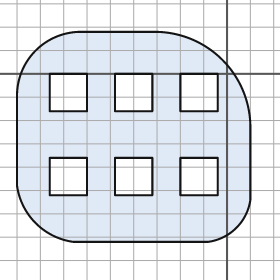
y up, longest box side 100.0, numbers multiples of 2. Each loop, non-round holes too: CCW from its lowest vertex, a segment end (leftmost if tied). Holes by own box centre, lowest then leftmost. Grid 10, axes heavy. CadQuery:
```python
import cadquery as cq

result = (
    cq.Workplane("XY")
    .moveTo(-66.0, -72.0)
    .lineTo(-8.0, -72.0)
    .threePointArc((4.0, -66.0), (10.0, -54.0))
    .lineTo(10.0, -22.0)
    .threePointArc((-2.0, 6.0), (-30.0, 18.0))
    .lineTo(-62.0, 18.0)
    .threePointArc((-82.0, 10.0), (-90.0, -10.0))
    .lineTo(-90.0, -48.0)
    .threePointArc((-82.0, -64.0), (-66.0, -72.0))
    .close()
    .moveTo(-76.0, -52.0)
    .lineTo(-60.0, -52.0)
    .lineTo(-60.0, -36.0)
    .lineTo(-76.0, -36.0)
    .close()
    .moveTo(-48.0, -52.0)
    .lineTo(-32.0, -52.0)
    .lineTo(-32.0, -36.0)
    .lineTo(-48.0, -36.0)
    .close()
    .moveTo(-20.0, -52.0)
    .lineTo(-4.0, -52.0)
    .lineTo(-4.0, -36.0)
    .lineTo(-20.0, -36.0)
    .close()
    .moveTo(-76.0, -16.0)
    .lineTo(-60.0, -16.0)
    .lineTo(-60.0, 0.0)
    .lineTo(-76.0, 0.0)
    .close()
    .moveTo(-48.0, -16.0)
    .lineTo(-32.0, -16.0)
    .lineTo(-32.0, 0.0)
    .lineTo(-48.0, 0.0)
    .close()
    .moveTo(-20.0, -16.0)
    .lineTo(-4.0, -16.0)
    .lineTo(-4.0, 0.0)
    .lineTo(-20.0, 0.0)
    .close()
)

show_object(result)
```